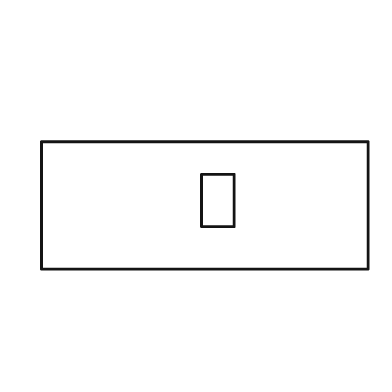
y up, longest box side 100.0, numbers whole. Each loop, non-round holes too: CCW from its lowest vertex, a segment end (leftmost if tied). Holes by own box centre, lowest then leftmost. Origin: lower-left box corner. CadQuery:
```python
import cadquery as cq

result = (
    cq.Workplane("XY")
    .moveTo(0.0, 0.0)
    .lineTo(100.0, 0.0)
    .lineTo(100.0, 39.0)
    .lineTo(0.0, 39.0)
    .close()
    .moveTo(49.0, 13.0)
    .lineTo(59.0, 13.0)
    .lineTo(59.0, 29.0)
    .lineTo(49.0, 29.0)
    .close()
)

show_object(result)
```